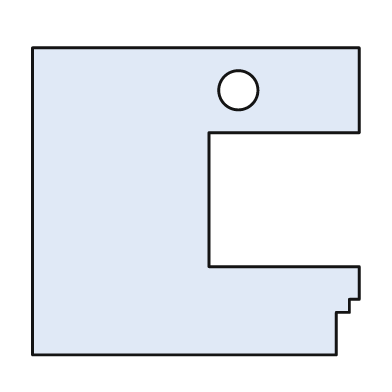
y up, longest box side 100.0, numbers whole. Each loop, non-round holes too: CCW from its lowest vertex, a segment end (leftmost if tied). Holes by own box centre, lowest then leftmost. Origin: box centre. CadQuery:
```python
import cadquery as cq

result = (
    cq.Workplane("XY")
    .moveTo(-50.0, -47.0)
    .lineTo(43.0, -47.0)
    .lineTo(43.0, -34.0)
    .lineTo(47.0, -34.0)
    .lineTo(47.0, -30.0)
    .lineTo(50.0, -30.0)
    .lineTo(50.0, -20.0)
    .lineTo(4.0, -20.0)
    .lineTo(4.0, 21.0)
    .lineTo(50.0, 21.0)
    .lineTo(50.0, 47.0)
    .lineTo(-50.0, 47.0)
    .close()
    .moveTo(13.0, 34.0)
    .circle(6.0)
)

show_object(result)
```